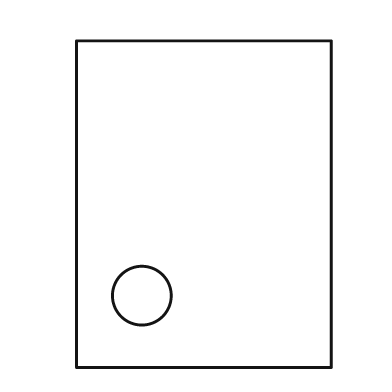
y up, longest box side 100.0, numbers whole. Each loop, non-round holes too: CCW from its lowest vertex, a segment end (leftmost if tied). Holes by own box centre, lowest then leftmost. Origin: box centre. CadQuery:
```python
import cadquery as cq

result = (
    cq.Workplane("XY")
    .moveTo(-39.0, -50.0)
    .lineTo(39.0, -50.0)
    .lineTo(39.0, 50.0)
    .lineTo(-39.0, 50.0)
    .close()
    .moveTo(-19.0, -28.0)
    .circle(9.0)
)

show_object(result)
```